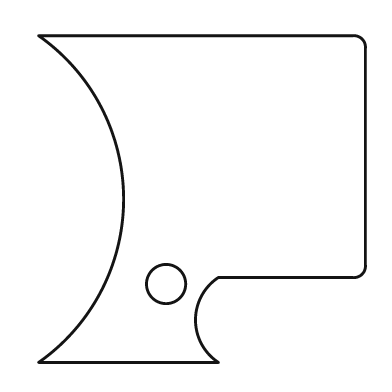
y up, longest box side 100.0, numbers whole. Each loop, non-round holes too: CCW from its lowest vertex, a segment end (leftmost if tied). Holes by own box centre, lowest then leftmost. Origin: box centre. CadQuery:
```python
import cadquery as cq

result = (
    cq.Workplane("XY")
    .moveTo(-50.0, -50.0)
    .lineTo(5.0, -50.0)
    .threePointArc((-2.0, -37.0), (5.0, -24.0))
    .lineTo(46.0, -24.0)
    .threePointArc((49.0, -23.0), (50.0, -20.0))
    .lineTo(50.0, 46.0)
    .threePointArc((49.0, 49.0), (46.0, 50.0))
    .lineTo(-50.0, 50.0)
    .threePointArc((-24.0, 0.0), (-50.0, -50.0))
    .close()
    .moveTo(-11.0, -26.0)
    .circle(6.0)
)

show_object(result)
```